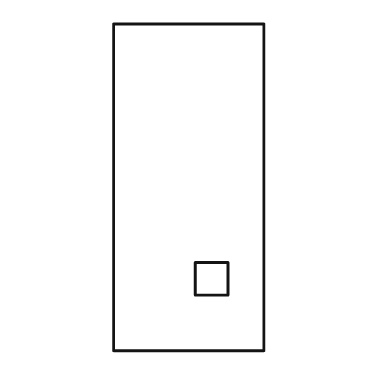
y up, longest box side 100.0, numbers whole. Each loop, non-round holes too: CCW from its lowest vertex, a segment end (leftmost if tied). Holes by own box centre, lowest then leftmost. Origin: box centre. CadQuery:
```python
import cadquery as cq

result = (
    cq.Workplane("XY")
    .moveTo(-23.0, -50.0)
    .lineTo(23.0, -50.0)
    .lineTo(23.0, 50.0)
    .lineTo(-23.0, 50.0)
    .close()
    .moveTo(2.0, -33.0)
    .lineTo(12.0, -33.0)
    .lineTo(12.0, -23.0)
    .lineTo(2.0, -23.0)
    .close()
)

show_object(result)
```